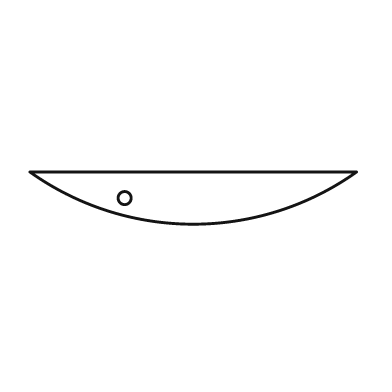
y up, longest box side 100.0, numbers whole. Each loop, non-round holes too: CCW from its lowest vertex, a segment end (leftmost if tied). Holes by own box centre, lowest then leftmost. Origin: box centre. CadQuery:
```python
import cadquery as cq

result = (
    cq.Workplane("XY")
    .moveTo(-50.0, 8.0)
    .threePointArc((0.0, -8.0), (50.0, 8.0))
    .close()
    .moveTo(-21.0, 0.0)
    .circle(2.0)
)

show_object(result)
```